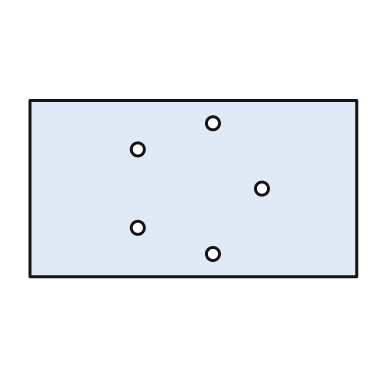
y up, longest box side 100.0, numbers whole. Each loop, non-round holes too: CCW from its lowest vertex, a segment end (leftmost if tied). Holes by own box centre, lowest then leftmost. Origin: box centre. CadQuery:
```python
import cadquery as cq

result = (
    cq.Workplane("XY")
    .moveTo(-50.0, -27.0)
    .lineTo(50.0, -27.0)
    .lineTo(50.0, 27.0)
    .lineTo(-50.0, 27.0)
    .close()
    .moveTo(6.0, -20.0)
    .circle(2.0)
    .moveTo(-17.0, -12.0)
    .circle(2.0)
    .moveTo(21.0, 0.0)
    .circle(2.0)
    .moveTo(-17.0, 12.0)
    .circle(2.0)
    .moveTo(6.0, 20.0)
    .circle(2.0)
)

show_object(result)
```